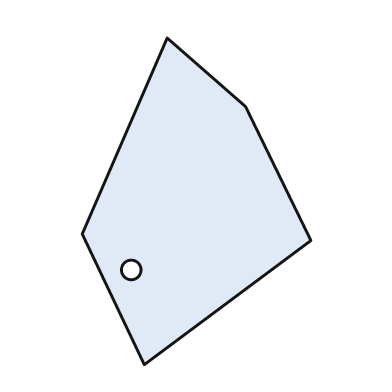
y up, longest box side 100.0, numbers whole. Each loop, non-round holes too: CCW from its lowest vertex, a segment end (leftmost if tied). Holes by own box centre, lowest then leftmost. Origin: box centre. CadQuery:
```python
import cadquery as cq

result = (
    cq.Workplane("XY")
    .moveTo(-16.0, -50.0)
    .lineTo(35.0, -12.0)
    .lineTo(15.0, 29.0)
    .lineTo(-9.0, 50.0)
    .lineTo(-35.0, -10.0)
    .close()
    .moveTo(-20.0, -21.0)
    .circle(3.0)
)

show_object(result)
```